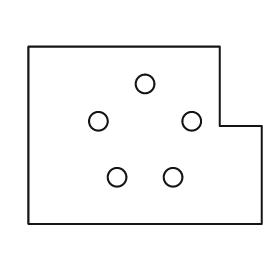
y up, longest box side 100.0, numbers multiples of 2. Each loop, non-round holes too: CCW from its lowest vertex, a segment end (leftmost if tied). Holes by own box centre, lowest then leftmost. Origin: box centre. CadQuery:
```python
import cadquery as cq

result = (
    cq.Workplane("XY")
    .moveTo(-50.0, -38.0)
    .lineTo(50.0, -38.0)
    .lineTo(50.0, 4.0)
    .lineTo(32.0, 4.0)
    .lineTo(32.0, 38.0)
    .lineTo(-50.0, 38.0)
    .close()
    .moveTo(-12.0, -18.0)
    .circle(4.0)
    .moveTo(12.0, -18.0)
    .circle(4.0)
    .moveTo(-20.0, 6.0)
    .circle(4.0)
    .moveTo(20.0, 6.0)
    .circle(4.0)
    .moveTo(0.0, 22.0)
    .circle(4.0)
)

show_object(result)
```